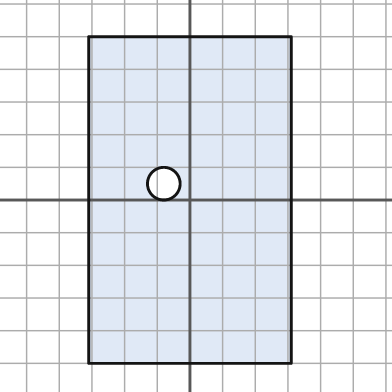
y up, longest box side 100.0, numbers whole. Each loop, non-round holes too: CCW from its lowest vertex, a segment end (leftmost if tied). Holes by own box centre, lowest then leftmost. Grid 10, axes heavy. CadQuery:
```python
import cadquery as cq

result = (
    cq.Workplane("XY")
    .moveTo(-31.0, -50.0)
    .lineTo(31.0, -50.0)
    .lineTo(31.0, 50.0)
    .lineTo(-31.0, 50.0)
    .close()
    .moveTo(-8.0, 5.0)
    .circle(5.0)
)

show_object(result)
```